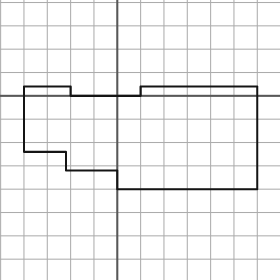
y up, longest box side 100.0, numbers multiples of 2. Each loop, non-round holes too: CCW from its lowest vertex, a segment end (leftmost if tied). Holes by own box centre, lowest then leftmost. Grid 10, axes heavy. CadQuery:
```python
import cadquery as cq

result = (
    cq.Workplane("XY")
    .moveTo(0.0, -40.0)
    .lineTo(60.0, -40.0)
    .lineTo(60.0, 4.0)
    .lineTo(10.0, 4.0)
    .lineTo(10.0, 0.0)
    .lineTo(-20.0, 0.0)
    .lineTo(-20.0, 4.0)
    .lineTo(-40.0, 4.0)
    .lineTo(-40.0, -24.0)
    .lineTo(-22.0, -24.0)
    .lineTo(-22.0, -32.0)
    .lineTo(0.0, -32.0)
    .close()
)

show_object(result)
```